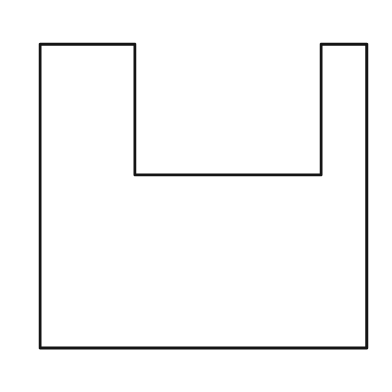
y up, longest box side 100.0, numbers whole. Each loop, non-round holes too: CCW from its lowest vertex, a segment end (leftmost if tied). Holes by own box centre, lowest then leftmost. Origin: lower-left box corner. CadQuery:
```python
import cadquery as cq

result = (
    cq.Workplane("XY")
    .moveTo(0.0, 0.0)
    .lineTo(100.0, 0.0)
    .lineTo(100.0, 93.0)
    .lineTo(86.0, 93.0)
    .lineTo(86.0, 53.0)
    .lineTo(29.0, 53.0)
    .lineTo(29.0, 93.0)
    .lineTo(0.0, 93.0)
    .close()
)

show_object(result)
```